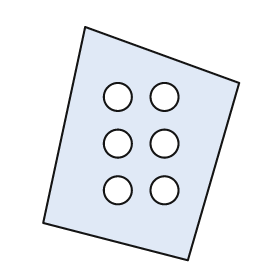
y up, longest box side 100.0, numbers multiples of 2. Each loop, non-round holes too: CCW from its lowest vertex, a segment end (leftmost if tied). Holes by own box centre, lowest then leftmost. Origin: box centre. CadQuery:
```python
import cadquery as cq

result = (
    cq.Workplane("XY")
    .moveTo(20.0, -50.0)
    .lineTo(42.0, 26.0)
    .lineTo(-24.0, 50.0)
    .lineTo(-42.0, -34.0)
    .close()
    .moveTo(-10.0, -20.0)
    .circle(6.0)
    .moveTo(10.0, -20.0)
    .circle(6.0)
    .moveTo(-10.0, 0.0)
    .circle(6.0)
    .moveTo(10.0, 0.0)
    .circle(6.0)
    .moveTo(-10.0, 20.0)
    .circle(6.0)
    .moveTo(10.0, 20.0)
    .circle(6.0)
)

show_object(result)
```